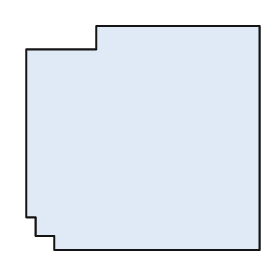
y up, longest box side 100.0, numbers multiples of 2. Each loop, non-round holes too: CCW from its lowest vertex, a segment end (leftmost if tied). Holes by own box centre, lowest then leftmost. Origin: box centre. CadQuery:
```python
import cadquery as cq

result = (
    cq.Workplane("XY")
    .moveTo(-38.0, -48.0)
    .lineTo(50.0, -48.0)
    .lineTo(50.0, 48.0)
    .lineTo(-20.0, 48.0)
    .lineTo(-20.0, 38.0)
    .lineTo(-50.0, 38.0)
    .lineTo(-50.0, -34.0)
    .lineTo(-46.0, -34.0)
    .lineTo(-46.0, -42.0)
    .lineTo(-38.0, -42.0)
    .close()
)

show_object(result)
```